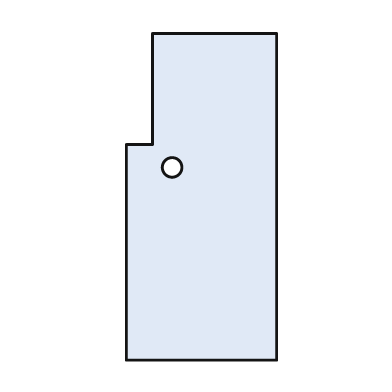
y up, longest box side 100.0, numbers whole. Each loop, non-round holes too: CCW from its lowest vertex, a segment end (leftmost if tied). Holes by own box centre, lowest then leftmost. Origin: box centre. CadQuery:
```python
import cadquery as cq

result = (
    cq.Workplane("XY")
    .moveTo(-23.0, -50.0)
    .lineTo(23.0, -50.0)
    .lineTo(23.0, 50.0)
    .lineTo(-15.0, 50.0)
    .lineTo(-15.0, 16.0)
    .lineTo(-23.0, 16.0)
    .close()
    .moveTo(-9.0, 9.0)
    .circle(3.0)
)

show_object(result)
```